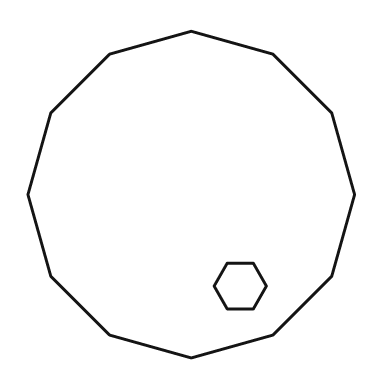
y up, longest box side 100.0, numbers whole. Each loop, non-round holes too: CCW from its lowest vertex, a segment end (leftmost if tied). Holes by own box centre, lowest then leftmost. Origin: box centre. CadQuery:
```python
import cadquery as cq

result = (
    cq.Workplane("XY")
    .moveTo(0.0, -50.0)
    .lineTo(25.0, -43.0)
    .lineTo(43.0, -25.0)
    .lineTo(50.0, 0.0)
    .lineTo(43.0, 25.0)
    .lineTo(25.0, 43.0)
    .lineTo(0.0, 50.0)
    .lineTo(-25.0, 43.0)
    .lineTo(-43.0, 25.0)
    .lineTo(-50.0, 0.0)
    .lineTo(-43.0, -25.0)
    .lineTo(-25.0, -43.0)
    .close()
    .moveTo(11.0, -35.0)
    .lineTo(19.0, -35.0)
    .lineTo(23.0, -28.0)
    .lineTo(19.0, -21.0)
    .lineTo(11.0, -21.0)
    .lineTo(7.0, -28.0)
    .close()
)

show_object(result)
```